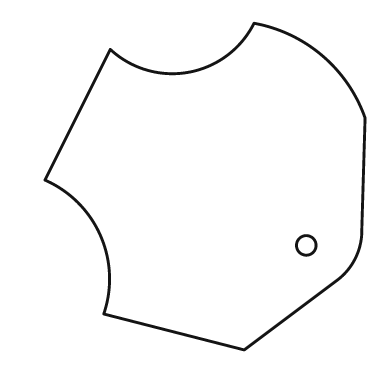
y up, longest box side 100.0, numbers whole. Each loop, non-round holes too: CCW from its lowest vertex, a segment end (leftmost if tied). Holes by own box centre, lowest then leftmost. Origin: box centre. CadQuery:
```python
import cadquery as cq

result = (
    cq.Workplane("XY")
    .moveTo(12.0, -50.0)
    .lineTo(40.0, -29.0)
    .threePointArc((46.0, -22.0), (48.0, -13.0))
    .lineTo(49.0, 21.0)
    .threePointArc((36.0, 40.0), (15.0, 50.0))
    .threePointArc((-5.0, 35.0), (-29.0, 42.0))
    .lineTo(-49.0, 2.0)
    .threePointArc((-32.0, -15.0), (-31.0, -39.0))
    .close()
    .moveTo(31.0, -18.0)
    .circle(3.0)
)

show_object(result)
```